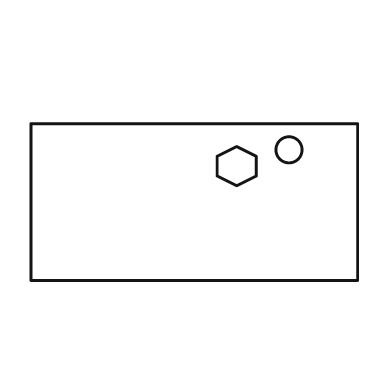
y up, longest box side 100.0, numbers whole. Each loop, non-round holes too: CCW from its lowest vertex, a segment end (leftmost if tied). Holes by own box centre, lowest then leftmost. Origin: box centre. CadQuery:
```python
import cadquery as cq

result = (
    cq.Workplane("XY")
    .moveTo(-50.0, -24.0)
    .lineTo(50.0, -24.0)
    .lineTo(50.0, 24.0)
    .lineTo(-50.0, 24.0)
    .close()
    .moveTo(13.0, 5.0)
    .lineTo(19.0, 8.0)
    .lineTo(19.0, 14.0)
    .lineTo(13.0, 17.0)
    .lineTo(7.0, 14.0)
    .lineTo(7.0, 8.0)
    .close()
    .moveTo(29.0, 16.0)
    .circle(4.0)
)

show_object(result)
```